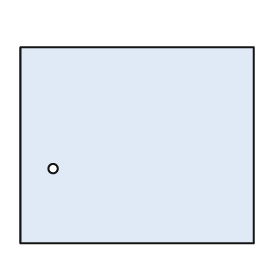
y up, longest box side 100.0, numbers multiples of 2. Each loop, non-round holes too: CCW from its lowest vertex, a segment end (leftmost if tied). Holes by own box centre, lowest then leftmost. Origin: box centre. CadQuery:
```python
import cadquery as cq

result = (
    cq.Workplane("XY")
    .moveTo(-50.0, -42.0)
    .lineTo(50.0, -42.0)
    .lineTo(50.0, 42.0)
    .lineTo(-50.0, 42.0)
    .close()
    .moveTo(-36.0, -10.0)
    .circle(2.0)
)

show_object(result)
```